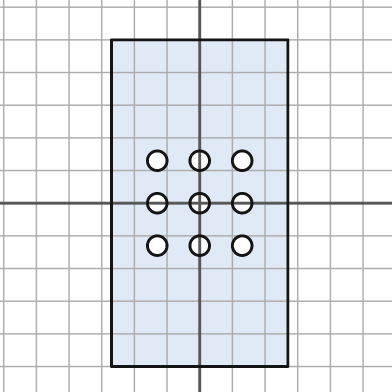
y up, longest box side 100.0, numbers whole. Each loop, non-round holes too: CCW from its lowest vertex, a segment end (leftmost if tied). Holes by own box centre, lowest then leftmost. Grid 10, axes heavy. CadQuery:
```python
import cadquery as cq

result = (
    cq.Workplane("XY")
    .moveTo(-27.0, -50.0)
    .lineTo(27.0, -50.0)
    .lineTo(27.0, 50.0)
    .lineTo(-27.0, 50.0)
    .close()
    .moveTo(-13.0, -13.0)
    .circle(3.0)
    .moveTo(0.0, -13.0)
    .circle(3.0)
    .moveTo(13.0, -13.0)
    .circle(3.0)
    .moveTo(-13.0, 0.0)
    .circle(3.0)
    .moveTo(0.0, 0.0)
    .circle(3.0)
    .moveTo(13.0, 0.0)
    .circle(3.0)
    .moveTo(-13.0, 13.0)
    .circle(3.0)
    .moveTo(0.0, 13.0)
    .circle(3.0)
    .moveTo(13.0, 13.0)
    .circle(3.0)
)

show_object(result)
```